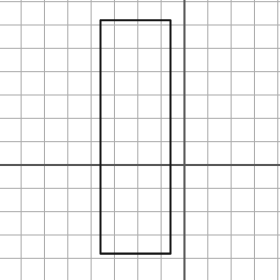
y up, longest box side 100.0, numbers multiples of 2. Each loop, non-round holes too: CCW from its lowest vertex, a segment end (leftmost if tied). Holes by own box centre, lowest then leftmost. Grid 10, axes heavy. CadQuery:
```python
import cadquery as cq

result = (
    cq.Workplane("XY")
    .moveTo(-36.0, -38.0)
    .lineTo(-6.0, -38.0)
    .lineTo(-6.0, 62.0)
    .lineTo(-36.0, 62.0)
    .close()
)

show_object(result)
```